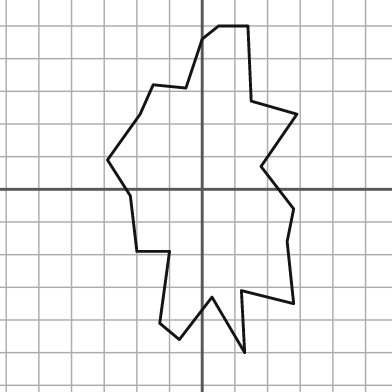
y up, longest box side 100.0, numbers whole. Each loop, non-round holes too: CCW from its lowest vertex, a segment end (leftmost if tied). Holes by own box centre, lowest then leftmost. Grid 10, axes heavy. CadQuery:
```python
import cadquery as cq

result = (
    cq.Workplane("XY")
    .moveTo(13.0, -50.0)
    .lineTo(12.0, -31.0)
    .lineTo(28.0, -35.0)
    .lineTo(26.0, -16.0)
    .lineTo(28.0, -6.0)
    .lineTo(18.0, 7.0)
    .lineTo(29.0, 23.0)
    .lineTo(15.0, 27.0)
    .lineTo(14.0, 50.0)
    .lineTo(5.0, 50.0)
    .lineTo(0.0, 46.0)
    .lineTo(-5.0, 31.0)
    .lineTo(-15.0, 32.0)
    .lineTo(-19.0, 23.0)
    .lineTo(-29.0, 9.0)
    .lineTo(-22.0, -2.0)
    .lineTo(-20.0, -19.0)
    .lineTo(-10.0, -19.0)
    .lineTo(-13.0, -41.0)
    .lineTo(-7.0, -46.0)
    .lineTo(3.0, -33.0)
    .close()
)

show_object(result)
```